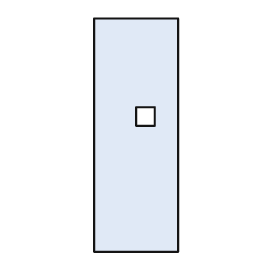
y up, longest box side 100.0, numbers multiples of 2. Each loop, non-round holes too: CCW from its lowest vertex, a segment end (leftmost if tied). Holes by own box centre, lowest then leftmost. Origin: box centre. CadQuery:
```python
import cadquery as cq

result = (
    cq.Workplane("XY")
    .moveTo(-18.0, -50.0)
    .lineTo(18.0, -50.0)
    .lineTo(18.0, 50.0)
    .lineTo(-18.0, 50.0)
    .close()
    .moveTo(0.0, 4.0)
    .lineTo(8.0, 4.0)
    .lineTo(8.0, 12.0)
    .lineTo(0.0, 12.0)
    .close()
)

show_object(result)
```